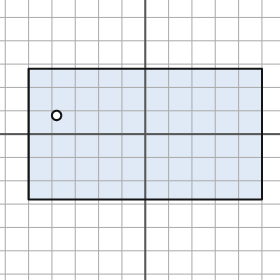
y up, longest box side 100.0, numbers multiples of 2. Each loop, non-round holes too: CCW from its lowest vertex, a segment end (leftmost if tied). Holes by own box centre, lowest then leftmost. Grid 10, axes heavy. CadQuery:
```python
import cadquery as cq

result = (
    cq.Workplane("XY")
    .moveTo(-50.0, -28.0)
    .lineTo(50.0, -28.0)
    .lineTo(50.0, 28.0)
    .lineTo(-50.0, 28.0)
    .close()
    .moveTo(-38.0, 8.0)
    .circle(2.0)
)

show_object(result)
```